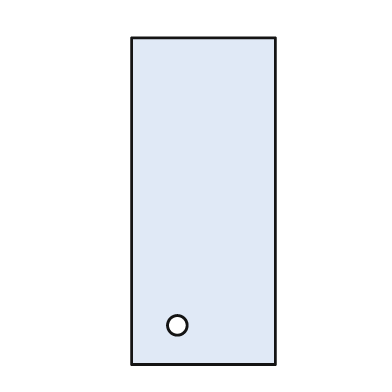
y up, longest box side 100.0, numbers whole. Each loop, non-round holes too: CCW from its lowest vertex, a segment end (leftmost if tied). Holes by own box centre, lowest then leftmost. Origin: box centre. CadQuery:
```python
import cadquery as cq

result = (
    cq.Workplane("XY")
    .moveTo(-22.0, -50.0)
    .lineTo(22.0, -50.0)
    .lineTo(22.0, 50.0)
    .lineTo(-22.0, 50.0)
    .close()
    .moveTo(-8.0, -38.0)
    .circle(3.0)
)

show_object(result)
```